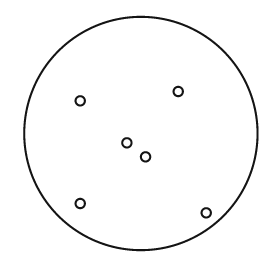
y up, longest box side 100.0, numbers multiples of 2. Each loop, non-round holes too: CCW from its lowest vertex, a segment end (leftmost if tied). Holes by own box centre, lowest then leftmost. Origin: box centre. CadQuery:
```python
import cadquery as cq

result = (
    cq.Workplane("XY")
    .moveTo(0.0, 0.0)
    .circle(50.0)
    .moveTo(28.0, -34.0)
    .circle(2.0)
    .moveTo(-26.0, -30.0)
    .circle(2.0)
    .moveTo(2.0, -10.0)
    .circle(2.0)
    .moveTo(-6.0, -4.0)
    .circle(2.0)
    .moveTo(-26.0, 14.0)
    .circle(2.0)
    .moveTo(16.0, 18.0)
    .circle(2.0)
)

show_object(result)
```